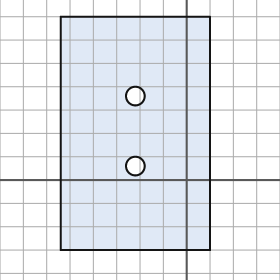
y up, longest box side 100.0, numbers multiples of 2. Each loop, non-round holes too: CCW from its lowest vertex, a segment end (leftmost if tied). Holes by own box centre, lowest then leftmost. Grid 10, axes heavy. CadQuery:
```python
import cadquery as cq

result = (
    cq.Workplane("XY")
    .moveTo(-54.0, -30.0)
    .lineTo(10.0, -30.0)
    .lineTo(10.0, 70.0)
    .lineTo(-54.0, 70.0)
    .close()
    .moveTo(-22.0, 6.0)
    .circle(4.0)
    .moveTo(-22.0, 36.0)
    .circle(4.0)
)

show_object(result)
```